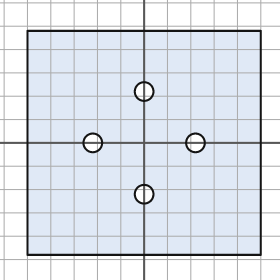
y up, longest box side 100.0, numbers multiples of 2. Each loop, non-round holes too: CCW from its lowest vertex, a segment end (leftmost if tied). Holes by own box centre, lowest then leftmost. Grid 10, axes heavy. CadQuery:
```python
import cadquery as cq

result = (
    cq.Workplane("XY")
    .moveTo(-50.0, -48.0)
    .lineTo(50.0, -48.0)
    .lineTo(50.0, 48.0)
    .lineTo(-50.0, 48.0)
    .close()
    .moveTo(0.0, -22.0)
    .circle(4.0)
    .moveTo(-22.0, 0.0)
    .circle(4.0)
    .moveTo(22.0, 0.0)
    .circle(4.0)
    .moveTo(0.0, 22.0)
    .circle(4.0)
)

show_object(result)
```